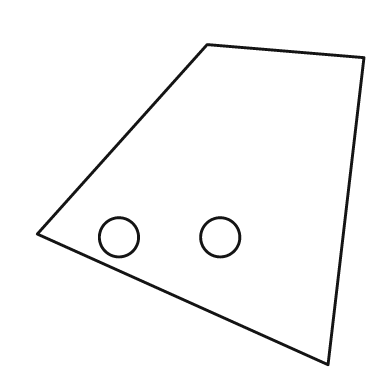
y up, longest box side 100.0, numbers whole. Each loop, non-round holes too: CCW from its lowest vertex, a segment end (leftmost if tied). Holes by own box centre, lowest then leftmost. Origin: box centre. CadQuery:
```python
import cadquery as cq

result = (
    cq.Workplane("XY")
    .moveTo(39.0, -49.0)
    .lineTo(50.0, 45.0)
    .lineTo(2.0, 49.0)
    .lineTo(-50.0, -9.0)
    .close()
    .moveTo(-25.0, -10.0)
    .circle(6.0)
    .moveTo(6.0, -10.0)
    .circle(6.0)
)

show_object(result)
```